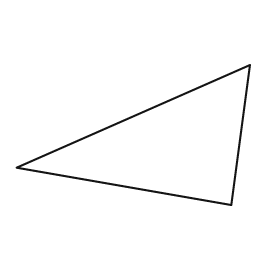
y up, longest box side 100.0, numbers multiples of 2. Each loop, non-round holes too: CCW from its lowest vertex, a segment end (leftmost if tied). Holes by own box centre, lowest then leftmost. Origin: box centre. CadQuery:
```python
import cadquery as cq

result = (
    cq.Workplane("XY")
    .moveTo(42.0, -30.0)
    .lineTo(50.0, 30.0)
    .lineTo(-50.0, -14.0)
    .close()
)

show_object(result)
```